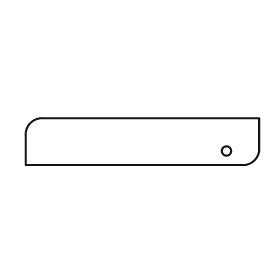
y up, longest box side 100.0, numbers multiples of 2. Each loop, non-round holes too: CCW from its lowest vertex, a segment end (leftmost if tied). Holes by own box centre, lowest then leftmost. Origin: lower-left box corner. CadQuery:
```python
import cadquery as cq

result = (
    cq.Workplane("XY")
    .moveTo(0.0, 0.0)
    .lineTo(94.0, 0.0)
    .threePointArc((98.0, 2.0), (100.0, 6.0))
    .lineTo(100.0, 20.0)
    .lineTo(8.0, 20.0)
    .threePointArc((2.0, 18.0), (0.0, 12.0))
    .close()
    .moveTo(86.0, 6.0)
    .circle(2.0)
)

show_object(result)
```